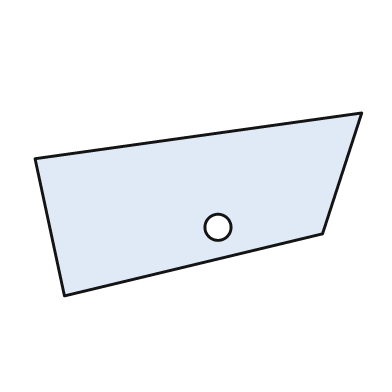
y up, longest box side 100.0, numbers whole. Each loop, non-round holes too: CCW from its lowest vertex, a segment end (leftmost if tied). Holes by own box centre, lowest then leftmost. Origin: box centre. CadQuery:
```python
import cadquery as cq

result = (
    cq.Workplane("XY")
    .moveTo(-41.0, -28.0)
    .lineTo(38.0, -9.0)
    .lineTo(50.0, 28.0)
    .lineTo(-50.0, 14.0)
    .close()
    .moveTo(6.0, -7.0)
    .circle(4.0)
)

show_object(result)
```